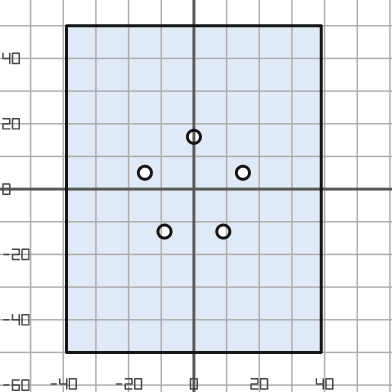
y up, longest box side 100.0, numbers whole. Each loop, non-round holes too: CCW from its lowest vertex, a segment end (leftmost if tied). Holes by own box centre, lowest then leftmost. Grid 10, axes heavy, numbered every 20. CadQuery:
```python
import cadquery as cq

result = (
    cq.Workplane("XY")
    .moveTo(-39.0, -50.0)
    .lineTo(39.0, -50.0)
    .lineTo(39.0, 50.0)
    .lineTo(-39.0, 50.0)
    .close()
    .moveTo(-9.0, -13.0)
    .circle(2.0)
    .moveTo(9.0, -13.0)
    .circle(2.0)
    .moveTo(-15.0, 5.0)
    .circle(2.0)
    .moveTo(15.0, 5.0)
    .circle(2.0)
    .moveTo(0.0, 16.0)
    .circle(2.0)
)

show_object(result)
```